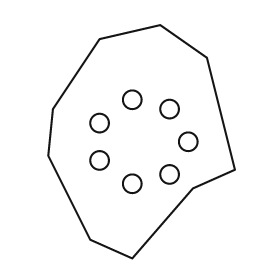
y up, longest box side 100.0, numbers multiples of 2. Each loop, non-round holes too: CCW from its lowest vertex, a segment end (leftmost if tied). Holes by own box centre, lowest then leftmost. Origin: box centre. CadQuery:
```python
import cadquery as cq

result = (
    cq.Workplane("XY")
    .moveTo(-4.0, -50.0)
    .lineTo(22.0, -20.0)
    .lineTo(40.0, -12.0)
    .lineTo(28.0, 36.0)
    .lineTo(8.0, 50.0)
    .lineTo(-18.0, 44.0)
    .lineTo(-38.0, 14.0)
    .lineTo(-40.0, -6.0)
    .lineTo(-22.0, -42.0)
    .close()
    .moveTo(-4.0, -18.0)
    .circle(4.0)
    .moveTo(12.0, -14.0)
    .circle(4.0)
    .moveTo(-18.0, -8.0)
    .circle(4.0)
    .moveTo(20.0, 0.0)
    .circle(4.0)
    .moveTo(-18.0, 8.0)
    .circle(4.0)
    .moveTo(12.0, 14.0)
    .circle(4.0)
    .moveTo(-4.0, 18.0)
    .circle(4.0)
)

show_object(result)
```